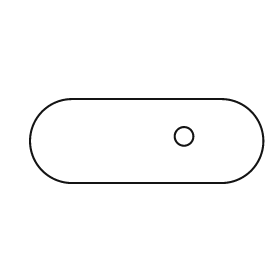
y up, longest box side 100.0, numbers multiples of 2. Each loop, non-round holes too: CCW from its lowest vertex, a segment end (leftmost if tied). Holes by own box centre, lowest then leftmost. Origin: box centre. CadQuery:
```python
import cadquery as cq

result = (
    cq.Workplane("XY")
    .moveTo(-32.0, -18.0)
    .lineTo(32.0, -18.0)
    .threePointArc((50.0, 0.0), (32.0, 18.0))
    .lineTo(-32.0, 18.0)
    .threePointArc((-50.0, 0.0), (-32.0, -18.0))
    .close()
    .moveTo(16.0, 2.0)
    .circle(4.0)
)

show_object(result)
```